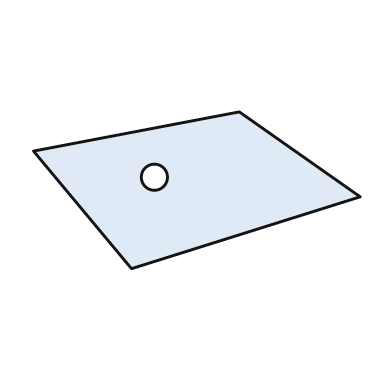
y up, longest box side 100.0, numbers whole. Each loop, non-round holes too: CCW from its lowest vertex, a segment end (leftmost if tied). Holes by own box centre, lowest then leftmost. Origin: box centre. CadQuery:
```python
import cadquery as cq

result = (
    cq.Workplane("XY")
    .moveTo(-20.0, -24.0)
    .lineTo(50.0, -2.0)
    .lineTo(13.0, 24.0)
    .lineTo(-50.0, 12.0)
    .close()
    .moveTo(-13.0, 4.0)
    .circle(4.0)
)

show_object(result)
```